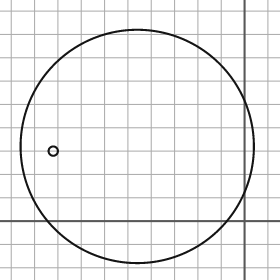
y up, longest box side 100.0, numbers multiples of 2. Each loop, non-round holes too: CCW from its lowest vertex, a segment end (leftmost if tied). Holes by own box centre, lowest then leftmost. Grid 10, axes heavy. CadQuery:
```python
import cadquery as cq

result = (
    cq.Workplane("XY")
    .moveTo(-46.0, 32.0)
    .circle(50.0)
    .moveTo(-82.0, 30.0)
    .circle(2.0)
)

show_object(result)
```